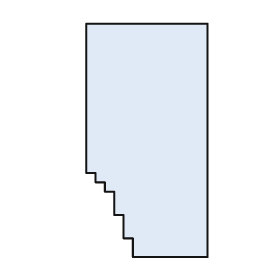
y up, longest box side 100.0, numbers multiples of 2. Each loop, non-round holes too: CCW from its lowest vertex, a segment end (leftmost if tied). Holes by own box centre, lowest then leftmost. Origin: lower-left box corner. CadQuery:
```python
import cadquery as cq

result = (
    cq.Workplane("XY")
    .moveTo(20.0, 0.0)
    .lineTo(52.0, 0.0)
    .lineTo(52.0, 100.0)
    .lineTo(0.0, 100.0)
    .lineTo(0.0, 36.0)
    .lineTo(4.0, 36.0)
    .lineTo(4.0, 32.0)
    .lineTo(8.0, 32.0)
    .lineTo(8.0, 28.0)
    .lineTo(12.0, 28.0)
    .lineTo(12.0, 18.0)
    .lineTo(16.0, 18.0)
    .lineTo(16.0, 8.0)
    .lineTo(20.0, 8.0)
    .close()
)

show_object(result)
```